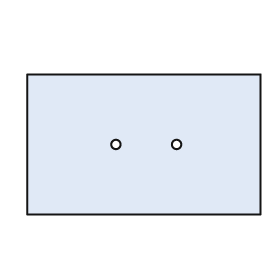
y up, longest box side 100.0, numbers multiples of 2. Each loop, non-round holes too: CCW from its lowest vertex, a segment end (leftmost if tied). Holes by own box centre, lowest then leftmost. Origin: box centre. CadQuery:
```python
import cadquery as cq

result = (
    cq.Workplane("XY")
    .moveTo(-50.0, -30.0)
    .lineTo(50.0, -30.0)
    .lineTo(50.0, 30.0)
    .lineTo(-50.0, 30.0)
    .close()
    .moveTo(-12.0, 0.0)
    .circle(2.0)
    .moveTo(14.0, 0.0)
    .circle(2.0)
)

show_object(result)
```